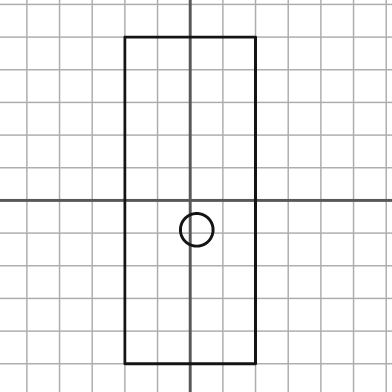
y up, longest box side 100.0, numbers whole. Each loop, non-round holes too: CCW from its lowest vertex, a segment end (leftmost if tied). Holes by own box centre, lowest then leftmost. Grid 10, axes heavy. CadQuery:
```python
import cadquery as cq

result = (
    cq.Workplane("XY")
    .moveTo(-20.0, -50.0)
    .lineTo(20.0, -50.0)
    .lineTo(20.0, 50.0)
    .lineTo(-20.0, 50.0)
    .close()
    .moveTo(2.0, -9.0)
    .circle(5.0)
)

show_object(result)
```